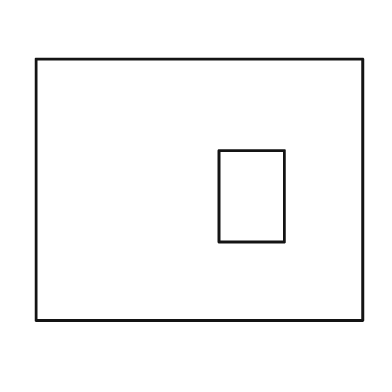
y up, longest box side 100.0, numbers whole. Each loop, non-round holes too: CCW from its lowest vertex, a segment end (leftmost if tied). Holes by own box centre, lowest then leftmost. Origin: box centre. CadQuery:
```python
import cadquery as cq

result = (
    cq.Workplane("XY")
    .moveTo(-50.0, -40.0)
    .lineTo(50.0, -40.0)
    .lineTo(50.0, 40.0)
    .lineTo(-50.0, 40.0)
    .close()
    .moveTo(6.0, -16.0)
    .lineTo(26.0, -16.0)
    .lineTo(26.0, 12.0)
    .lineTo(6.0, 12.0)
    .close()
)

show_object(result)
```